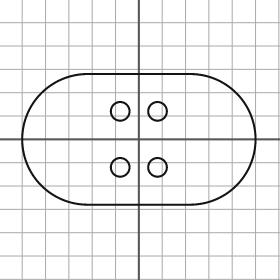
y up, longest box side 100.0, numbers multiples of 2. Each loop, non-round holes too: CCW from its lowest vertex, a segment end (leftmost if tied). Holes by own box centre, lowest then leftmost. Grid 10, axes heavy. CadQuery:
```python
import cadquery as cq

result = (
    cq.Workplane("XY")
    .moveTo(-22.0, -28.0)
    .lineTo(22.0, -28.0)
    .threePointArc((50.0, 0.0), (22.0, 28.0))
    .lineTo(-22.0, 28.0)
    .threePointArc((-50.0, 0.0), (-22.0, -28.0))
    .close()
    .moveTo(-8.0, -12.0)
    .circle(4.0)
    .moveTo(8.0, -12.0)
    .circle(4.0)
    .moveTo(-8.0, 12.0)
    .circle(4.0)
    .moveTo(8.0, 12.0)
    .circle(4.0)
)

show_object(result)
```